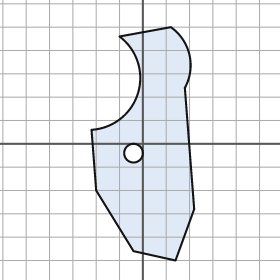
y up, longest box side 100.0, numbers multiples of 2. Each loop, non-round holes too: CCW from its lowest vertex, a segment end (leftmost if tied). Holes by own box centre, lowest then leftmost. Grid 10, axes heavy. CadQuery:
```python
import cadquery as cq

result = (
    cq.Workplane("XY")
    .moveTo(14.0, -50.0)
    .lineTo(22.0, -28.0)
    .lineTo(18.0, 24.0)
    .threePointArc((20.0, 38.0), (12.0, 50.0))
    .lineTo(-10.0, 46.0)
    .threePointArc((-2.0, 22.0), (-22.0, 6.0))
    .lineTo(-20.0, -20.0)
    .lineTo(-4.0, -46.0)
    .close()
    .moveTo(-4.0, -4.0)
    .circle(4.0)
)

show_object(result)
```